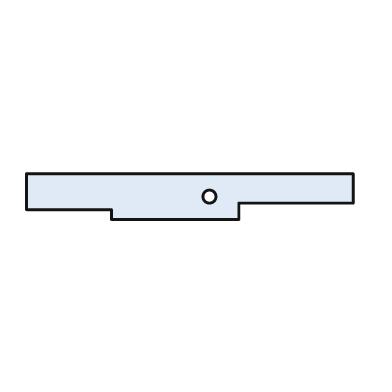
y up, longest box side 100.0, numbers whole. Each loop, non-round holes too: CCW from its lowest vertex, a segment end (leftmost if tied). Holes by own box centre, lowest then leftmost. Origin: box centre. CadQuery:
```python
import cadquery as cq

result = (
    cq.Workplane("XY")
    .moveTo(-24.0, -7.0)
    .lineTo(15.0, -7.0)
    .lineTo(15.0, -2.0)
    .lineTo(50.0, -2.0)
    .lineTo(50.0, 7.0)
    .lineTo(-50.0, 7.0)
    .lineTo(-50.0, -4.0)
    .lineTo(-24.0, -4.0)
    .close()
    .moveTo(6.0, 0.0)
    .circle(2.0)
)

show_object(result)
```